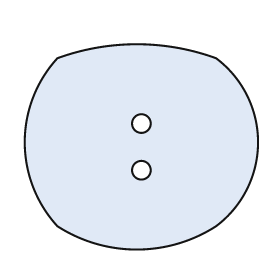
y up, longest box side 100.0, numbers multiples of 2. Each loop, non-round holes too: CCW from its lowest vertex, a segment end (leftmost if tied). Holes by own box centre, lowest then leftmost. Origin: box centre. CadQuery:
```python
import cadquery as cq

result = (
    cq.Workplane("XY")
    .moveTo(-36.0, -34.0)
    .threePointArc((-2.0, -44.0), (32.0, -34.0))
    .threePointArc((50.0, 2.0), (32.0, 38.0))
    .threePointArc((-2.0, 44.0), (-36.0, 38.0))
    .threePointArc((-50.0, 2.0), (-36.0, -34.0))
    .close()
    .moveTo(0.0, -10.0)
    .circle(4.0)
    .moveTo(0.0, 10.0)
    .circle(4.0)
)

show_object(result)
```